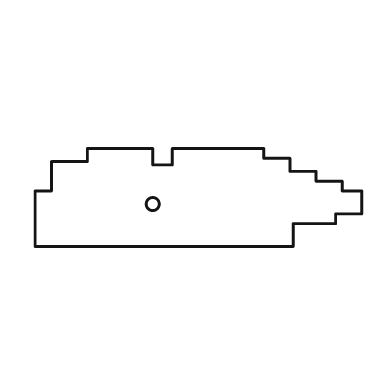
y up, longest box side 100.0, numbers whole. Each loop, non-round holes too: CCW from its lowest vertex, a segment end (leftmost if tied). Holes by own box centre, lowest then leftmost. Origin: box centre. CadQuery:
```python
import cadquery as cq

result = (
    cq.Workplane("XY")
    .moveTo(-50.0, -15.0)
    .lineTo(29.0, -15.0)
    .lineTo(29.0, -8.0)
    .lineTo(42.0, -8.0)
    .lineTo(42.0, -5.0)
    .lineTo(50.0, -5.0)
    .lineTo(50.0, 2.0)
    .lineTo(44.0, 2.0)
    .lineTo(44.0, 5.0)
    .lineTo(36.0, 5.0)
    .lineTo(36.0, 8.0)
    .lineTo(28.0, 8.0)
    .lineTo(28.0, 12.0)
    .lineTo(20.0, 12.0)
    .lineTo(20.0, 15.0)
    .lineTo(-8.0, 15.0)
    .lineTo(-8.0, 10.0)
    .lineTo(-14.0, 10.0)
    .lineTo(-14.0, 15.0)
    .lineTo(-34.0, 15.0)
    .lineTo(-34.0, 11.0)
    .lineTo(-45.0, 11.0)
    .lineTo(-45.0, 2.0)
    .lineTo(-50.0, 2.0)
    .close()
    .moveTo(-14.0, -2.0)
    .circle(2.0)
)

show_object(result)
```